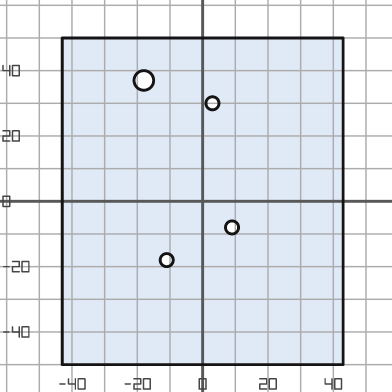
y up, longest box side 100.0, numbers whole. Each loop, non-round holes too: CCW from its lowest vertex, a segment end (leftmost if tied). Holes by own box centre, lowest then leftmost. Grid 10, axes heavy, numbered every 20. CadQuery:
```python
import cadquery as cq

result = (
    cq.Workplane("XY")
    .moveTo(-43.0, -50.0)
    .lineTo(43.0, -50.0)
    .lineTo(43.0, 50.0)
    .lineTo(-43.0, 50.0)
    .close()
    .moveTo(-11.0, -18.0)
    .circle(2.0)
    .moveTo(9.0, -8.0)
    .circle(2.0)
    .moveTo(3.0, 30.0)
    .circle(2.0)
    .moveTo(-18.0, 37.0)
    .circle(3.0)
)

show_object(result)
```